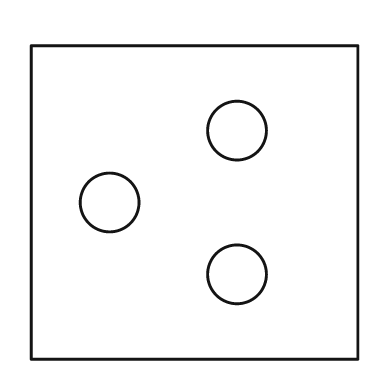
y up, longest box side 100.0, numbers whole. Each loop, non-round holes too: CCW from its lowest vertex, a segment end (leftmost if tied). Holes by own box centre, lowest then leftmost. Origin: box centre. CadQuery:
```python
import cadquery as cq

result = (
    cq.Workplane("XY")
    .moveTo(-50.0, -48.0)
    .lineTo(50.0, -48.0)
    .lineTo(50.0, 48.0)
    .lineTo(-50.0, 48.0)
    .close()
    .moveTo(13.0, -22.0)
    .circle(9.0)
    .moveTo(-26.0, 0.0)
    .circle(9.0)
    .moveTo(13.0, 22.0)
    .circle(9.0)
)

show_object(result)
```